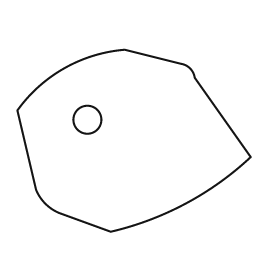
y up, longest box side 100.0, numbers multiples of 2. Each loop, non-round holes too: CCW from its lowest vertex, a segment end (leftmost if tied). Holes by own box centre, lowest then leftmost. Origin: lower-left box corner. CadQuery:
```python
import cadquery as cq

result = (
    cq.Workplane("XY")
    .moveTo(40.0, 0.0)
    .threePointArc((72.0, 12.0), (100.0, 32.0))
    .lineTo(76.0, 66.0)
    .threePointArc((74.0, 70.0), (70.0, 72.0))
    .lineTo(46.0, 78.0)
    .threePointArc((20.0, 70.0), (0.0, 52.0))
    .lineTo(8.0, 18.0)
    .threePointArc((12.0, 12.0), (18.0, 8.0))
    .close()
    .moveTo(30.0, 48.0)
    .circle(6.0)
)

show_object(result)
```